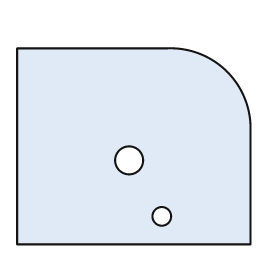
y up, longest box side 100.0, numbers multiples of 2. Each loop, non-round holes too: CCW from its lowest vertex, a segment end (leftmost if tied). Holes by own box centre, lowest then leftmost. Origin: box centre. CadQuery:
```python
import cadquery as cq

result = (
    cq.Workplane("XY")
    .moveTo(-50.0, -42.0)
    .lineTo(50.0, -42.0)
    .lineTo(50.0, 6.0)
    .threePointArc((40.0, 32.0), (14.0, 42.0))
    .lineTo(-50.0, 42.0)
    .close()
    .moveTo(12.0, -30.0)
    .circle(4.0)
    .moveTo(-2.0, -6.0)
    .circle(6.0)
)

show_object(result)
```